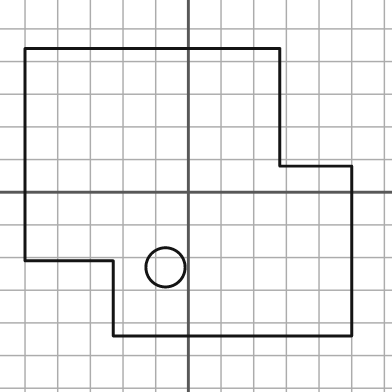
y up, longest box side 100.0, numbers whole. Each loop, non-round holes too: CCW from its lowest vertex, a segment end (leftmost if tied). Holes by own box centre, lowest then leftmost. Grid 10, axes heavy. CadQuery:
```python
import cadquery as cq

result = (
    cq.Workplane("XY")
    .moveTo(-23.0, -44.0)
    .lineTo(50.0, -44.0)
    .lineTo(50.0, 8.0)
    .lineTo(28.0, 8.0)
    .lineTo(28.0, 44.0)
    .lineTo(-50.0, 44.0)
    .lineTo(-50.0, -21.0)
    .lineTo(-23.0, -21.0)
    .close()
    .moveTo(-7.0, -23.0)
    .circle(6.0)
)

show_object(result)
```